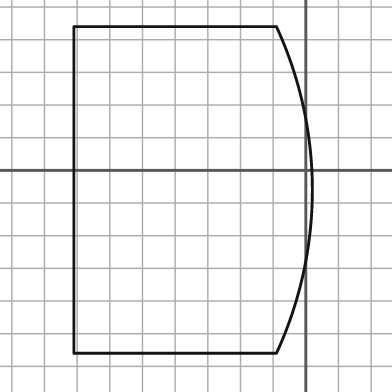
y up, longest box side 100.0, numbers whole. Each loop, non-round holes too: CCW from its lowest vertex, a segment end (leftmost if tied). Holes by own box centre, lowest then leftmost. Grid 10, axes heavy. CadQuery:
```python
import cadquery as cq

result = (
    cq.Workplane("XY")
    .moveTo(-71.0, -56.0)
    .lineTo(-9.0, -56.0)
    .threePointArc((2.0, -6.0), (-9.0, 44.0))
    .lineTo(-71.0, 44.0)
    .close()
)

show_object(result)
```